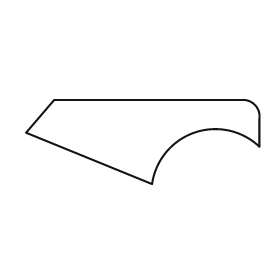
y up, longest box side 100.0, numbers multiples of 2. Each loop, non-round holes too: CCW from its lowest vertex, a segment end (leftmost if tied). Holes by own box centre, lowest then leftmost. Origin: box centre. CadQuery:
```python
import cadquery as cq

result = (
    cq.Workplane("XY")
    .moveTo(4.0, -18.0)
    .threePointArc((22.0, 4.0), (50.0, -2.0))
    .lineTo(50.0, 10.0)
    .threePointArc((48.0, 16.0), (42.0, 18.0))
    .lineTo(-38.0, 18.0)
    .lineTo(-50.0, 4.0)
    .close()
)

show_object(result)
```